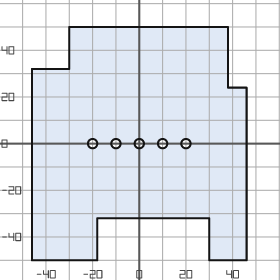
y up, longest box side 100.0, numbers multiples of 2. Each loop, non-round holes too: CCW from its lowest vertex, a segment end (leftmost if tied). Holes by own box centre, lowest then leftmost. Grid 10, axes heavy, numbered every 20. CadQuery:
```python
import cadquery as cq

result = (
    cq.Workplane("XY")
    .moveTo(-46.0, -50.0)
    .lineTo(-18.0, -50.0)
    .lineTo(-18.0, -32.0)
    .lineTo(30.0, -32.0)
    .lineTo(30.0, -50.0)
    .lineTo(46.0, -50.0)
    .lineTo(46.0, 24.0)
    .lineTo(38.0, 24.0)
    .lineTo(38.0, 50.0)
    .lineTo(-30.0, 50.0)
    .lineTo(-30.0, 32.0)
    .lineTo(-46.0, 32.0)
    .close()
    .moveTo(-20.0, 0.0)
    .circle(2.0)
    .moveTo(-10.0, 0.0)
    .circle(2.0)
    .moveTo(0.0, 0.0)
    .circle(2.0)
    .moveTo(10.0, 0.0)
    .circle(2.0)
    .moveTo(20.0, 0.0)
    .circle(2.0)
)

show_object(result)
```